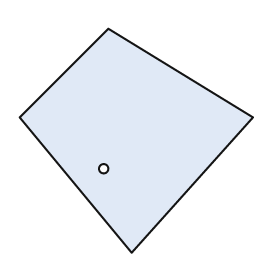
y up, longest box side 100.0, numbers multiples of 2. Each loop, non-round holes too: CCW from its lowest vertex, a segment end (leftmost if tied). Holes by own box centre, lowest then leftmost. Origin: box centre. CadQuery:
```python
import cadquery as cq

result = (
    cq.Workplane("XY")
    .moveTo(-2.0, -48.0)
    .lineTo(50.0, 10.0)
    .lineTo(-12.0, 48.0)
    .lineTo(-50.0, 10.0)
    .close()
    .moveTo(-14.0, -12.0)
    .circle(2.0)
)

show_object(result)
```